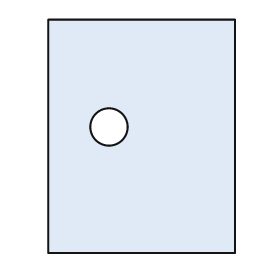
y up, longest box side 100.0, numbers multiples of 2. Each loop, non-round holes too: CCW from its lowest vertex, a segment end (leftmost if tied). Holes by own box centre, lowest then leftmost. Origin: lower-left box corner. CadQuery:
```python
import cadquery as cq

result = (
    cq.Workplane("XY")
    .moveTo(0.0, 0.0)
    .lineTo(80.0, 0.0)
    .lineTo(80.0, 100.0)
    .lineTo(0.0, 100.0)
    .close()
    .moveTo(26.0, 54.0)
    .circle(8.0)
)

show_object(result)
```